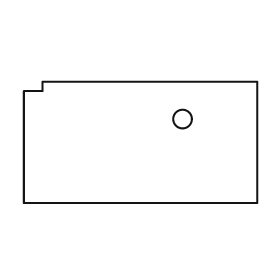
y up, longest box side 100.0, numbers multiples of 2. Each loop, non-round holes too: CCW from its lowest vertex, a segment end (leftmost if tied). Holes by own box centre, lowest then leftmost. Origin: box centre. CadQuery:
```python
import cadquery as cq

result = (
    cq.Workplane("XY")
    .moveTo(-50.0, -26.0)
    .lineTo(50.0, -26.0)
    .lineTo(50.0, 26.0)
    .lineTo(-42.0, 26.0)
    .lineTo(-42.0, 22.0)
    .lineTo(-50.0, 22.0)
    .close()
    .moveTo(18.0, 10.0)
    .circle(4.0)
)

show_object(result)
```